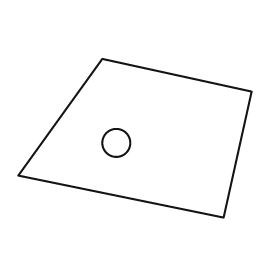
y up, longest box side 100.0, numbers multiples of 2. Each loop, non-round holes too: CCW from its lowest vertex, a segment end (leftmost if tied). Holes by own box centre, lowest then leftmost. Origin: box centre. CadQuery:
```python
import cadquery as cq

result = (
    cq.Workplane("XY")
    .moveTo(38.0, -34.0)
    .lineTo(50.0, 20.0)
    .lineTo(-14.0, 34.0)
    .lineTo(-50.0, -16.0)
    .close()
    .moveTo(-8.0, -2.0)
    .circle(6.0)
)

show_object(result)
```